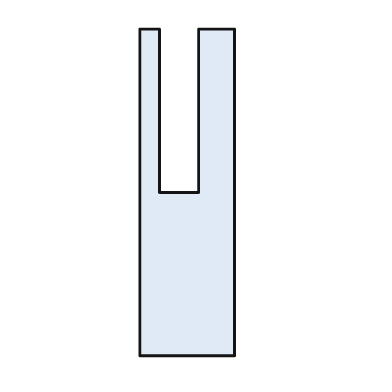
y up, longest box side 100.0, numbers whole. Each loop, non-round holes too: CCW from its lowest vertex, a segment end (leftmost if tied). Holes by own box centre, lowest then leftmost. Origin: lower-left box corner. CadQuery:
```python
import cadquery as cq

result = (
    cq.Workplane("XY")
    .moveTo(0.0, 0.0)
    .lineTo(29.0, 0.0)
    .lineTo(29.0, 100.0)
    .lineTo(18.0, 100.0)
    .lineTo(18.0, 50.0)
    .lineTo(6.0, 50.0)
    .lineTo(6.0, 100.0)
    .lineTo(0.0, 100.0)
    .close()
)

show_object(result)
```